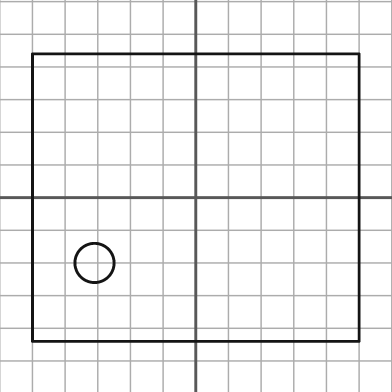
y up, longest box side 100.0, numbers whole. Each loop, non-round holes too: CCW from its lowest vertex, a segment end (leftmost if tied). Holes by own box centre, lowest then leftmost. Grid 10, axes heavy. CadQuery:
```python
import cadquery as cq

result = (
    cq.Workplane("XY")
    .moveTo(-50.0, -44.0)
    .lineTo(50.0, -44.0)
    .lineTo(50.0, 44.0)
    .lineTo(-50.0, 44.0)
    .close()
    .moveTo(-31.0, -20.0)
    .circle(6.0)
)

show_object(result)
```